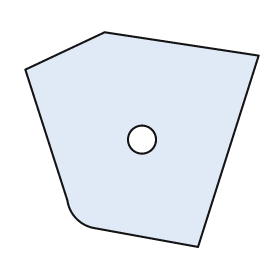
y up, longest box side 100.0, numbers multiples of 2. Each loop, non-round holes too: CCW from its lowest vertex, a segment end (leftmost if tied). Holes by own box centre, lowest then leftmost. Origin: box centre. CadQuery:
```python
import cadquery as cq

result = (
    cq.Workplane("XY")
    .moveTo(24.0, -46.0)
    .lineTo(50.0, 36.0)
    .lineTo(-16.0, 46.0)
    .lineTo(-50.0, 30.0)
    .lineTo(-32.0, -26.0)
    .threePointArc((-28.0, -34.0), (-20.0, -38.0))
    .close()
    .moveTo(0.0, 0.0)
    .circle(6.0)
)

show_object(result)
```